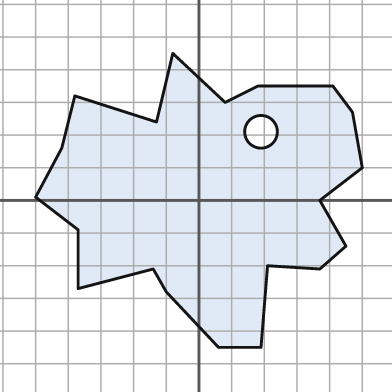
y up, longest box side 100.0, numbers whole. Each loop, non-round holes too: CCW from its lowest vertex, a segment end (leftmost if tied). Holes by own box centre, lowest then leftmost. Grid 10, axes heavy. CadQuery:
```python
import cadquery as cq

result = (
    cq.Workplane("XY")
    .moveTo(6.0, -45.0)
    .lineTo(19.0, -45.0)
    .lineTo(21.0, -20.0)
    .lineTo(37.0, -21.0)
    .lineTo(45.0, -14.0)
    .lineTo(37.0, 0.0)
    .lineTo(50.0, 10.0)
    .lineTo(47.0, 27.0)
    .lineTo(41.0, 35.0)
    .lineTo(18.0, 35.0)
    .lineTo(8.0, 30.0)
    .lineTo(-8.0, 45.0)
    .lineTo(-13.0, 24.0)
    .lineTo(-38.0, 32.0)
    .lineTo(-42.0, 16.0)
    .lineTo(-50.0, 1.0)
    .lineTo(-37.0, -9.0)
    .lineTo(-37.0, -27.0)
    .lineTo(-14.0, -21.0)
    .lineTo(-10.0, -28.0)
    .close()
    .moveTo(19.0, 21.0)
    .circle(5.0)
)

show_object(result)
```